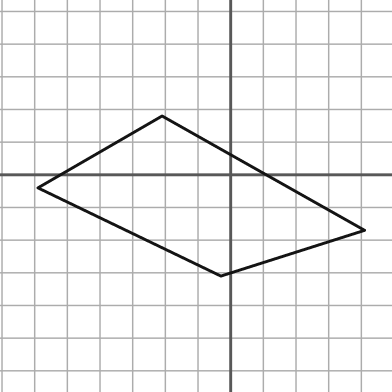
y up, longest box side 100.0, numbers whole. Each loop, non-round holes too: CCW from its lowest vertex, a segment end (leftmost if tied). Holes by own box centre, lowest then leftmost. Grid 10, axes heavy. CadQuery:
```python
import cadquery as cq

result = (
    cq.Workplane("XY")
    .moveTo(-3.0, -31.0)
    .lineTo(41.0, -17.0)
    .lineTo(-21.0, 18.0)
    .lineTo(-59.0, -4.0)
    .close()
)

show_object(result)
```